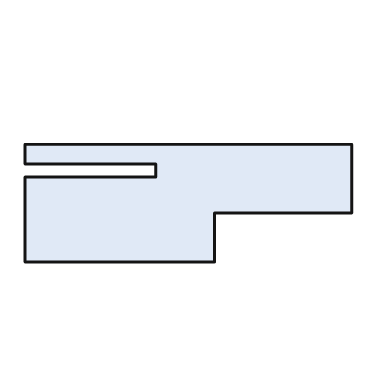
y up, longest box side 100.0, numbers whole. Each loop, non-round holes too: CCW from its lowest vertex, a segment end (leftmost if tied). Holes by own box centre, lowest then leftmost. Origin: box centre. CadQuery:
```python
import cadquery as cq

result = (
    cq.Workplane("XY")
    .moveTo(-50.0, -18.0)
    .lineTo(8.0, -18.0)
    .lineTo(8.0, -3.0)
    .lineTo(50.0, -3.0)
    .lineTo(50.0, 18.0)
    .lineTo(-50.0, 18.0)
    .lineTo(-50.0, 12.0)
    .lineTo(-10.0, 12.0)
    .lineTo(-10.0, 8.0)
    .lineTo(-50.0, 8.0)
    .close()
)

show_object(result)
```